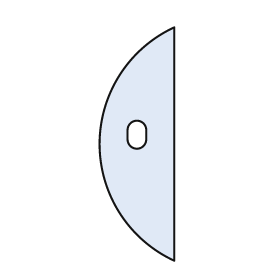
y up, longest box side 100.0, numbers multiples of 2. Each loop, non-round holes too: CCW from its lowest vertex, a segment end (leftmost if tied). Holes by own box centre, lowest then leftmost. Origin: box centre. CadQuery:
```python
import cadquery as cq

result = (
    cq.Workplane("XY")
    .moveTo(16.0, -50.0)
    .lineTo(16.0, 50.0)
    .threePointArc((-16.0, 0.0), (16.0, -50.0))
    .close()
    .moveTo(-4.0, 2.0)
    .threePointArc((0.0, -2.0), (4.0, 2.0))
    .lineTo(4.0, 6.0)
    .threePointArc((0.0, 10.0), (-4.0, 6.0))
    .close()
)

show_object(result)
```